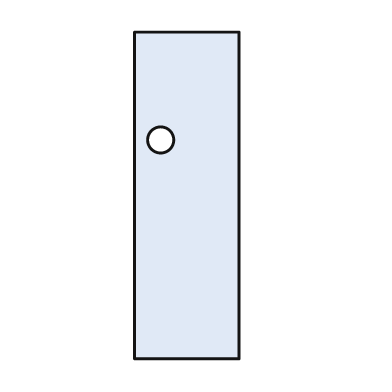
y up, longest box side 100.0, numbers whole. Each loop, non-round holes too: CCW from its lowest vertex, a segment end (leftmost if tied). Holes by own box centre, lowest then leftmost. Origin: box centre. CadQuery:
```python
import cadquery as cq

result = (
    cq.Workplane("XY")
    .moveTo(-16.0, -50.0)
    .lineTo(16.0, -50.0)
    .lineTo(16.0, 50.0)
    .lineTo(-16.0, 50.0)
    .close()
    .moveTo(-8.0, 17.0)
    .circle(4.0)
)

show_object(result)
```